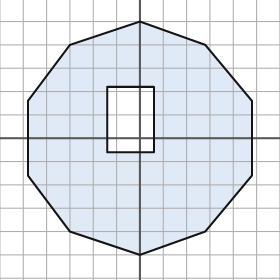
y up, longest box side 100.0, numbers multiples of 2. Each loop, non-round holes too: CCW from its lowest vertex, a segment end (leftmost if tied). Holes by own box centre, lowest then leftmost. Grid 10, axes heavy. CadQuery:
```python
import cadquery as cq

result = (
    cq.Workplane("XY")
    .moveTo(0.0, -50.0)
    .lineTo(28.0, -40.0)
    .lineTo(48.0, -16.0)
    .lineTo(48.0, 16.0)
    .lineTo(28.0, 40.0)
    .lineTo(0.0, 50.0)
    .lineTo(-30.0, 40.0)
    .lineTo(-48.0, 16.0)
    .lineTo(-48.0, -16.0)
    .lineTo(-30.0, -40.0)
    .close()
    .moveTo(-14.0, -6.0)
    .lineTo(6.0, -6.0)
    .lineTo(6.0, 22.0)
    .lineTo(-14.0, 22.0)
    .close()
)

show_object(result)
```